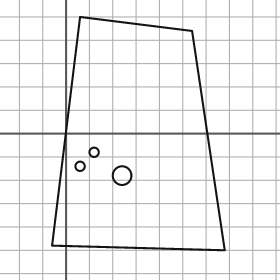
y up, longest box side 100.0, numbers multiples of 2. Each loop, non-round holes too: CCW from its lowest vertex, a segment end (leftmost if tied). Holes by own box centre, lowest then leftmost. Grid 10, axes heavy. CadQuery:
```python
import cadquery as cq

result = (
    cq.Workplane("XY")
    .moveTo(68.0, -50.0)
    .lineTo(54.0, 44.0)
    .lineTo(6.0, 50.0)
    .lineTo(-6.0, -48.0)
    .close()
    .moveTo(24.0, -18.0)
    .circle(4.0)
    .moveTo(6.0, -14.0)
    .circle(2.0)
    .moveTo(12.0, -8.0)
    .circle(2.0)
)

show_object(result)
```